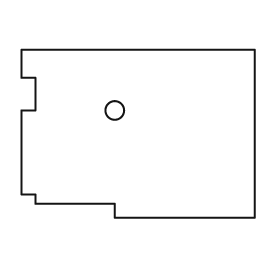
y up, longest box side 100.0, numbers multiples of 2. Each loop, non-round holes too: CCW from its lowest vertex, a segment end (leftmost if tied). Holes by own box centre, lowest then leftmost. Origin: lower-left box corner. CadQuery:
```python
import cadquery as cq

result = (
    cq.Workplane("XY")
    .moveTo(40.0, 0.0)
    .lineTo(100.0, 0.0)
    .lineTo(100.0, 72.0)
    .lineTo(0.0, 72.0)
    .lineTo(0.0, 60.0)
    .lineTo(6.0, 60.0)
    .lineTo(6.0, 46.0)
    .lineTo(0.0, 46.0)
    .lineTo(0.0, 10.0)
    .lineTo(6.0, 10.0)
    .lineTo(6.0, 6.0)
    .lineTo(40.0, 6.0)
    .close()
    .moveTo(40.0, 46.0)
    .circle(4.0)
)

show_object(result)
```